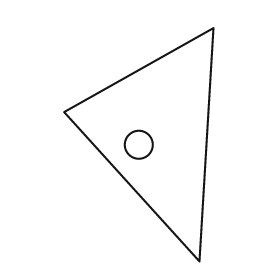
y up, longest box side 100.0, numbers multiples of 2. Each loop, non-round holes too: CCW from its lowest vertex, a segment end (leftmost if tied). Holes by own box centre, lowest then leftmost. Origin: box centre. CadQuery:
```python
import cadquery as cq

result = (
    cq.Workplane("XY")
    .moveTo(26.0, -50.0)
    .lineTo(32.0, 50.0)
    .lineTo(-32.0, 14.0)
    .close()
    .moveTo(0.0, 0.0)
    .circle(6.0)
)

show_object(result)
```